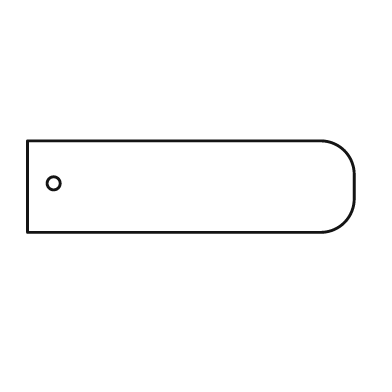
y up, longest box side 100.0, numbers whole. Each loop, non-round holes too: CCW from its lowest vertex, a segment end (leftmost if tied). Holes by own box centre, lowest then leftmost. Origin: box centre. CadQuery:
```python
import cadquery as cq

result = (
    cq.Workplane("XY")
    .moveTo(-50.0, -14.0)
    .lineTo(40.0, -14.0)
    .threePointArc((47.0, -11.0), (50.0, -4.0))
    .lineTo(50.0, 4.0)
    .threePointArc((47.0, 11.0), (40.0, 14.0))
    .lineTo(-50.0, 14.0)
    .close()
    .moveTo(-42.0, 1.0)
    .circle(2.0)
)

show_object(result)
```